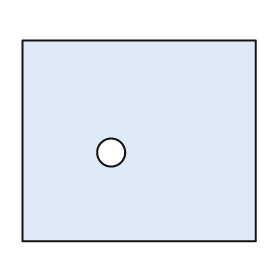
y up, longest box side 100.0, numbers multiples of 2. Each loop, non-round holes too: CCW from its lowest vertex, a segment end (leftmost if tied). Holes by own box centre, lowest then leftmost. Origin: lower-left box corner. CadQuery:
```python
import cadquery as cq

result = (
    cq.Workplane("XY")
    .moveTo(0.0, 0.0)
    .lineTo(100.0, 0.0)
    .lineTo(100.0, 86.0)
    .lineTo(0.0, 86.0)
    .close()
    .moveTo(38.0, 38.0)
    .circle(6.0)
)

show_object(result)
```